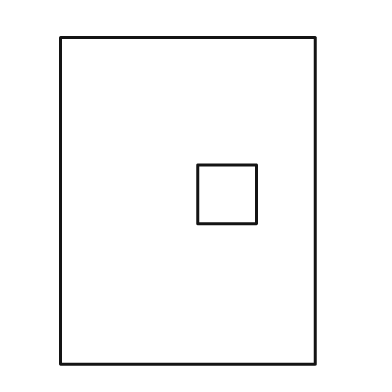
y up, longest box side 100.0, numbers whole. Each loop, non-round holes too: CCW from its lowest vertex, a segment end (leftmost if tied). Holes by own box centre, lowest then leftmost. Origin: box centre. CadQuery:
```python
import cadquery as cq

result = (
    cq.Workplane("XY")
    .moveTo(-39.0, -50.0)
    .lineTo(39.0, -50.0)
    .lineTo(39.0, 50.0)
    .lineTo(-39.0, 50.0)
    .close()
    .moveTo(3.0, -7.0)
    .lineTo(21.0, -7.0)
    .lineTo(21.0, 11.0)
    .lineTo(3.0, 11.0)
    .close()
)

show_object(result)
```